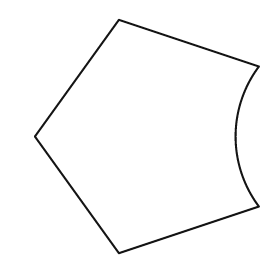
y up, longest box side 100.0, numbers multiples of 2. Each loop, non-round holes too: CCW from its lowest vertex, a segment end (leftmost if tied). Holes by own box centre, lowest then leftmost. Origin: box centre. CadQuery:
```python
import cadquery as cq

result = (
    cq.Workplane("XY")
    .moveTo(-12.0, -50.0)
    .lineTo(48.0, -30.0)
    .threePointArc((38.0, 0.0), (48.0, 30.0))
    .lineTo(-12.0, 50.0)
    .lineTo(-48.0, 0.0)
    .close()
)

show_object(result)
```